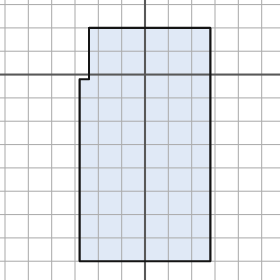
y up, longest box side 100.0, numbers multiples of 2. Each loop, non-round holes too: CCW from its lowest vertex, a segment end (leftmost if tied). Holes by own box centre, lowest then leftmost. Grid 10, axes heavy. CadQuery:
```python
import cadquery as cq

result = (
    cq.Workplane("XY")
    .moveTo(-28.0, -80.0)
    .lineTo(28.0, -80.0)
    .lineTo(28.0, 20.0)
    .lineTo(-24.0, 20.0)
    .lineTo(-24.0, -2.0)
    .lineTo(-28.0, -2.0)
    .close()
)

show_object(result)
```